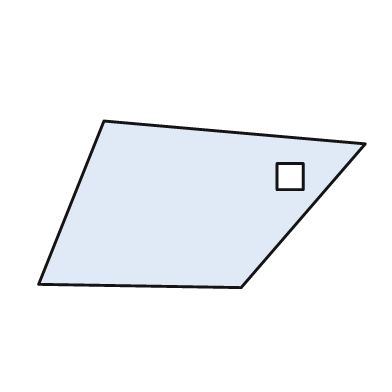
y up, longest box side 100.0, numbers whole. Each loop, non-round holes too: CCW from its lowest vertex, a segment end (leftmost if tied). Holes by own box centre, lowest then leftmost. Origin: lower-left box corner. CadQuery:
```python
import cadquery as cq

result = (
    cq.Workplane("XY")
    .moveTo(62.0, 0.0)
    .lineTo(100.0, 44.0)
    .lineTo(20.0, 51.0)
    .lineTo(0.0, 1.0)
    .close()
    .moveTo(73.0, 30.0)
    .lineTo(81.0, 30.0)
    .lineTo(81.0, 38.0)
    .lineTo(73.0, 38.0)
    .close()
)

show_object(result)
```